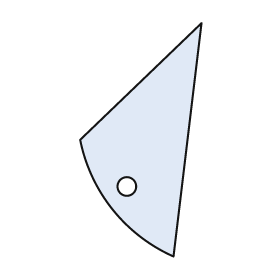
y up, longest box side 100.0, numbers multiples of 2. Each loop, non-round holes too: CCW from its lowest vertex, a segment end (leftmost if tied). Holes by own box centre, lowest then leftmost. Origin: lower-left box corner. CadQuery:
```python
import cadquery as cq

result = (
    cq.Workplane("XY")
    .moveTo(40.0, 0.0)
    .lineTo(52.0, 100.0)
    .lineTo(0.0, 50.0)
    .threePointArc((14.0, 20.0), (40.0, 0.0))
    .close()
    .moveTo(20.0, 30.0)
    .circle(4.0)
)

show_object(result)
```